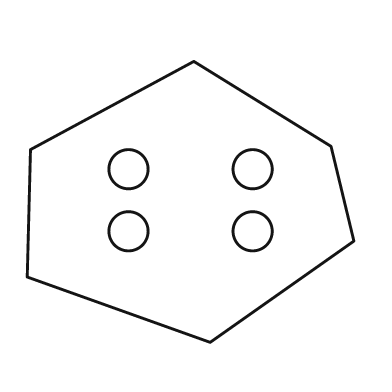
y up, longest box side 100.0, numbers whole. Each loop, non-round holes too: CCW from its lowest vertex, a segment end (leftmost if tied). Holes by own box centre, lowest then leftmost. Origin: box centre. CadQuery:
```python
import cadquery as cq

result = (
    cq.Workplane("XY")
    .moveTo(6.0, -43.0)
    .lineTo(50.0, -12.0)
    .lineTo(43.0, 17.0)
    .lineTo(1.0, 43.0)
    .lineTo(-49.0, 16.0)
    .lineTo(-50.0, -23.0)
    .close()
    .moveTo(-19.0, -9.0)
    .circle(6.0)
    .moveTo(19.0, -9.0)
    .circle(6.0)
    .moveTo(-19.0, 10.0)
    .circle(6.0)
    .moveTo(19.0, 10.0)
    .circle(6.0)
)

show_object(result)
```